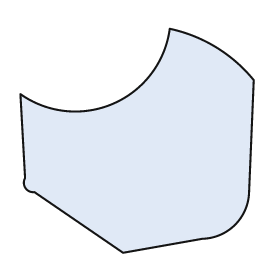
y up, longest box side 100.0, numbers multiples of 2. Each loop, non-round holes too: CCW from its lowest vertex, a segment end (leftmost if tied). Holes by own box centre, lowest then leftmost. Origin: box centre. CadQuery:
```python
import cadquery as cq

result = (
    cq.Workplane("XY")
    .moveTo(-6.0, -48.0)
    .lineTo(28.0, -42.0)
    .threePointArc((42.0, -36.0), (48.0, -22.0))
    .lineTo(50.0, 26.0)
    .threePointArc((34.0, 40.0), (14.0, 48.0))
    .threePointArc((-10.0, 16.0), (-50.0, 20.0))
    .lineTo(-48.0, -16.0)
    .threePointArc((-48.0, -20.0), (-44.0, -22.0))
    .close()
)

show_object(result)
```